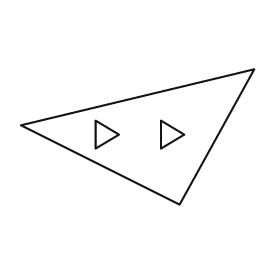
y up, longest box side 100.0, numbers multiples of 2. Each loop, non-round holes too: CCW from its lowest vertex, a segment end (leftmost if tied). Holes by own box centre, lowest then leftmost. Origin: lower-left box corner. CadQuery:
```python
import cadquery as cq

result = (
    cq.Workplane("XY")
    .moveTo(68.0, 0.0)
    .lineTo(100.0, 58.0)
    .lineTo(0.0, 34.0)
    .close()
    .moveTo(32.0, 24.0)
    .lineTo(42.0, 30.0)
    .lineTo(32.0, 36.0)
    .close()
    .moveTo(60.0, 24.0)
    .lineTo(70.0, 30.0)
    .lineTo(60.0, 36.0)
    .close()
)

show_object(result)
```